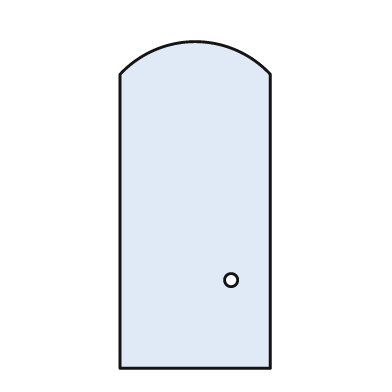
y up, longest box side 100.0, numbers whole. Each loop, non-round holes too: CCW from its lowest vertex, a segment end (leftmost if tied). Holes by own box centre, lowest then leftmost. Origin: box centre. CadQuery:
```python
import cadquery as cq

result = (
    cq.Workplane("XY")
    .moveTo(-23.0, -50.0)
    .lineTo(23.0, -50.0)
    .lineTo(23.0, 40.0)
    .threePointArc((0.0, 50.0), (-23.0, 40.0))
    .close()
    .moveTo(11.0, -23.0)
    .circle(2.0)
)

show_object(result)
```